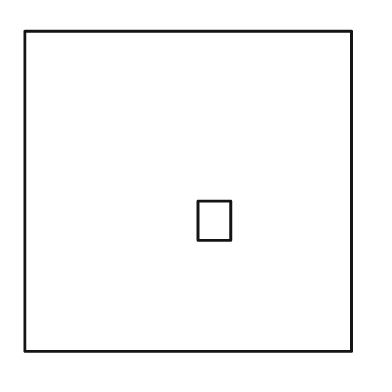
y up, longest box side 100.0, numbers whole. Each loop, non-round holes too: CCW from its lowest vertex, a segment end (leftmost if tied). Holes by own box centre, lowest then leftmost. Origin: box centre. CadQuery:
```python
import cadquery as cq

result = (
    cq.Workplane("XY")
    .moveTo(-50.0, -49.0)
    .lineTo(50.0, -49.0)
    .lineTo(50.0, 49.0)
    .lineTo(-50.0, 49.0)
    .close()
    .moveTo(3.0, -15.0)
    .lineTo(13.0, -15.0)
    .lineTo(13.0, -3.0)
    .lineTo(3.0, -3.0)
    .close()
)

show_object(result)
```